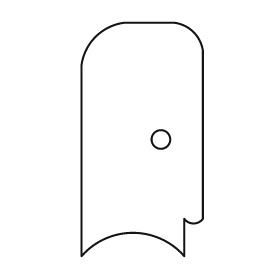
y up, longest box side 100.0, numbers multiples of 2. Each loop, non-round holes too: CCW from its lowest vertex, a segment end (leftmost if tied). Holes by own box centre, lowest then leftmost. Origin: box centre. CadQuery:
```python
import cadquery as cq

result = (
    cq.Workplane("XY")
    .moveTo(-26.0, -50.0)
    .threePointArc((-4.0, -40.0), (18.0, -50.0))
    .lineTo(18.0, -34.0)
    .threePointArc((22.0, -36.0), (26.0, -34.0))
    .lineTo(26.0, 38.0)
    .threePointArc((22.0, 46.0), (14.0, 50.0))
    .lineTo(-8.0, 50.0)
    .threePointArc((-20.0, 44.0), (-26.0, 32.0))
    .close()
    .moveTo(8.0, 0.0)
    .circle(4.0)
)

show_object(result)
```